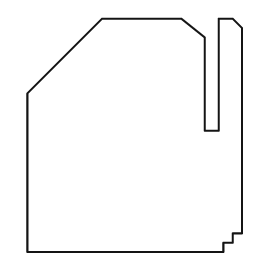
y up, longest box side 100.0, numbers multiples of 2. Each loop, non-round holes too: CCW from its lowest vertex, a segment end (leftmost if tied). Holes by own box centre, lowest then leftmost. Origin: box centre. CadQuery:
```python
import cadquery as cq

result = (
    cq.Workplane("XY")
    .moveTo(-46.0, -50.0)
    .lineTo(38.0, -50.0)
    .lineTo(38.0, -46.0)
    .lineTo(42.0, -46.0)
    .lineTo(42.0, -42.0)
    .lineTo(46.0, -42.0)
    .lineTo(46.0, 46.0)
    .lineTo(42.0, 50.0)
    .lineTo(36.0, 50.0)
    .lineTo(36.0, 2.0)
    .lineTo(30.0, 2.0)
    .lineTo(30.0, 42.0)
    .lineTo(20.0, 50.0)
    .lineTo(-14.0, 50.0)
    .lineTo(-46.0, 18.0)
    .close()
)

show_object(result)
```